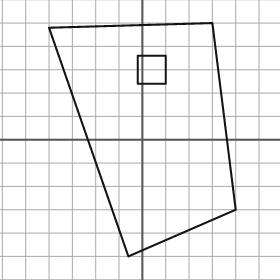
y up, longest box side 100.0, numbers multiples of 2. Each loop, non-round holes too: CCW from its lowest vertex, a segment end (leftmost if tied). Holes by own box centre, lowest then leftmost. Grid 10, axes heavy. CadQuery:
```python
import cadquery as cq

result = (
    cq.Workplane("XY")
    .moveTo(-6.0, -50.0)
    .lineTo(40.0, -30.0)
    .lineTo(30.0, 50.0)
    .lineTo(-40.0, 48.0)
    .close()
    .moveTo(-2.0, 24.0)
    .lineTo(10.0, 24.0)
    .lineTo(10.0, 36.0)
    .lineTo(-2.0, 36.0)
    .close()
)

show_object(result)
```